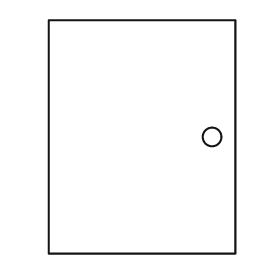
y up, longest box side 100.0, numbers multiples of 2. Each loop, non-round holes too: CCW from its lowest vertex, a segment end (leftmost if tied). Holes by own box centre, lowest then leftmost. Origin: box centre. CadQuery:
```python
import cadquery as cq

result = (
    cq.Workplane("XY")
    .moveTo(-40.0, -50.0)
    .lineTo(40.0, -50.0)
    .lineTo(40.0, 50.0)
    .lineTo(-40.0, 50.0)
    .close()
    .moveTo(30.0, 0.0)
    .circle(4.0)
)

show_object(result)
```